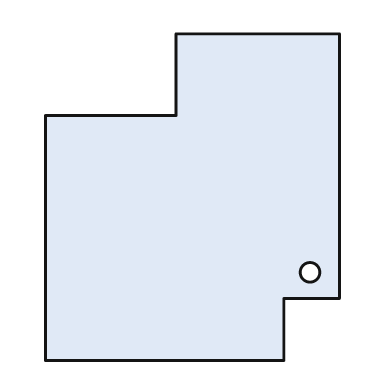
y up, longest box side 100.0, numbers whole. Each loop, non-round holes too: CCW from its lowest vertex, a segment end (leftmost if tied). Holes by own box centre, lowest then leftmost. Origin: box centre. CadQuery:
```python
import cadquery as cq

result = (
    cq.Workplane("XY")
    .moveTo(-45.0, -50.0)
    .lineTo(28.0, -50.0)
    .lineTo(28.0, -31.0)
    .lineTo(45.0, -31.0)
    .lineTo(45.0, 50.0)
    .lineTo(-5.0, 50.0)
    .lineTo(-5.0, 25.0)
    .lineTo(-45.0, 25.0)
    .close()
    .moveTo(36.0, -23.0)
    .circle(3.0)
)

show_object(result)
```